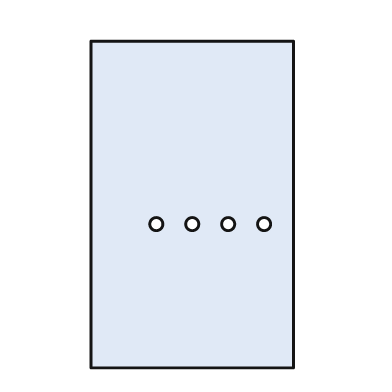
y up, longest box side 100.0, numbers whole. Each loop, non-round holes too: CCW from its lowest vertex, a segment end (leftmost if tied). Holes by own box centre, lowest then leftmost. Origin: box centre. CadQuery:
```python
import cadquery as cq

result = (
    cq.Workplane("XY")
    .moveTo(-31.0, -50.0)
    .lineTo(31.0, -50.0)
    .lineTo(31.0, 50.0)
    .lineTo(-31.0, 50.0)
    .close()
    .moveTo(-11.0, -6.0)
    .circle(2.0)
    .moveTo(0.0, -6.0)
    .circle(2.0)
    .moveTo(11.0, -6.0)
    .circle(2.0)
    .moveTo(22.0, -6.0)
    .circle(2.0)
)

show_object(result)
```